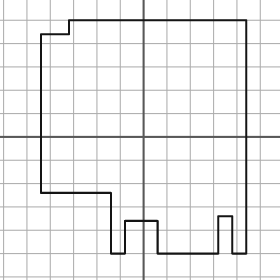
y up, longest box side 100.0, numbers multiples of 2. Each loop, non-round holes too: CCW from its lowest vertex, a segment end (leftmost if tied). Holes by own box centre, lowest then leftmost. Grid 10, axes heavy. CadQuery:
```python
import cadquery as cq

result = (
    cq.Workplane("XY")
    .moveTo(-14.0, -50.0)
    .lineTo(-8.0, -50.0)
    .lineTo(-8.0, -36.0)
    .lineTo(6.0, -36.0)
    .lineTo(6.0, -50.0)
    .lineTo(32.0, -50.0)
    .lineTo(32.0, -34.0)
    .lineTo(38.0, -34.0)
    .lineTo(38.0, -50.0)
    .lineTo(44.0, -50.0)
    .lineTo(44.0, 50.0)
    .lineTo(-32.0, 50.0)
    .lineTo(-32.0, 44.0)
    .lineTo(-44.0, 44.0)
    .lineTo(-44.0, -24.0)
    .lineTo(-14.0, -24.0)
    .close()
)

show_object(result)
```